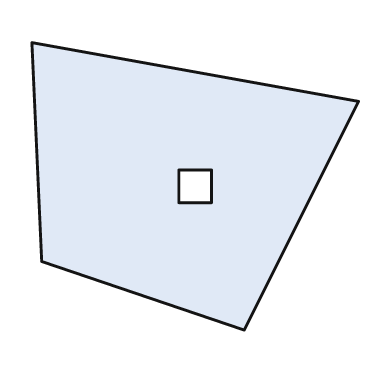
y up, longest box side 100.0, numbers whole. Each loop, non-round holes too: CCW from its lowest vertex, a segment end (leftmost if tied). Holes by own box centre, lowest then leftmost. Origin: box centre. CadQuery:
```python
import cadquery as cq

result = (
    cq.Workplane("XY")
    .moveTo(15.0, -44.0)
    .lineTo(50.0, 26.0)
    .lineTo(-50.0, 44.0)
    .lineTo(-47.0, -23.0)
    .close()
    .moveTo(-5.0, -5.0)
    .lineTo(5.0, -5.0)
    .lineTo(5.0, 5.0)
    .lineTo(-5.0, 5.0)
    .close()
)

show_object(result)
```